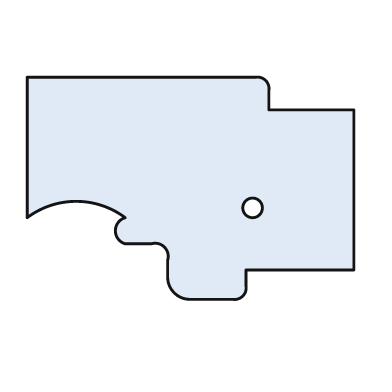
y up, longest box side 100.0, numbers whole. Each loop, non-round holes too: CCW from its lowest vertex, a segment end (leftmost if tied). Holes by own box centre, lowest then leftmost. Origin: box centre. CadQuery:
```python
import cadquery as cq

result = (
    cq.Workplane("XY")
    .moveTo(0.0, -34.0)
    .lineTo(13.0, -34.0)
    .threePointArc((16.0, -33.0), (17.0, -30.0))
    .lineTo(17.0, -25.0)
    .lineTo(50.0, -25.0)
    .lineTo(50.0, 24.0)
    .lineTo(24.0, 24.0)
    .lineTo(24.0, 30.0)
    .threePointArc((23.0, 33.0), (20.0, 34.0))
    .lineTo(-50.0, 34.0)
    .lineTo(-50.0, -9.0)
    .threePointArc((-35.0, -4.0), (-20.0, -9.0))
    .threePointArc((-23.0, -13.0), (-20.0, -17.0))
    .lineTo(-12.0, -17.0)
    .threePointArc((-8.0, -18.0), (-7.0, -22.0))
    .lineTo(-7.0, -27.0)
    .threePointArc((-5.0, -32.0), (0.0, -34.0))
    .close()
    .moveTo(19.0, -6.0)
    .circle(3.0)
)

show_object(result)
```